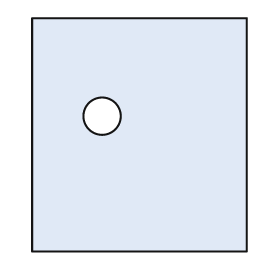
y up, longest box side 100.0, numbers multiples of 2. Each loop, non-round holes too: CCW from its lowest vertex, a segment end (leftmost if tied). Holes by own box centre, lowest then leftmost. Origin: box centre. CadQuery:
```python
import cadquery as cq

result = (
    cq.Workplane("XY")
    .moveTo(-46.0, -50.0)
    .lineTo(46.0, -50.0)
    .lineTo(46.0, 50.0)
    .lineTo(-46.0, 50.0)
    .close()
    .moveTo(-16.0, 8.0)
    .circle(8.0)
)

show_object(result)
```